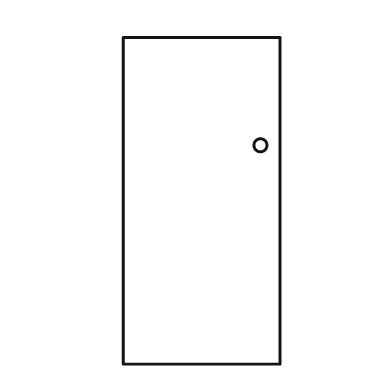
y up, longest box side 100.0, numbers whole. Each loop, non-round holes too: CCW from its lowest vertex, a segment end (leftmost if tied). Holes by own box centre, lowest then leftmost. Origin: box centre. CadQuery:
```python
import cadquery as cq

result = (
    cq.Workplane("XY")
    .moveTo(-24.0, -50.0)
    .lineTo(24.0, -50.0)
    .lineTo(24.0, 50.0)
    .lineTo(-24.0, 50.0)
    .close()
    .moveTo(18.0, 17.0)
    .circle(2.0)
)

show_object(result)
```